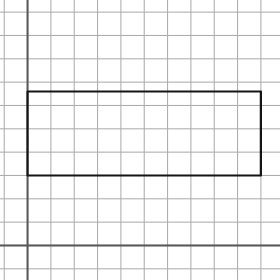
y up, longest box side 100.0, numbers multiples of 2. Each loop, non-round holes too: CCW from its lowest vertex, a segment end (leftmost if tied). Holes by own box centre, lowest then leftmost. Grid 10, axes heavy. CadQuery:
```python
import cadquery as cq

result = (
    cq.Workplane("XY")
    .moveTo(0.0, 30.0)
    .lineTo(100.0, 30.0)
    .lineTo(100.0, 66.0)
    .lineTo(0.0, 66.0)
    .close()
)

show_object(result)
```